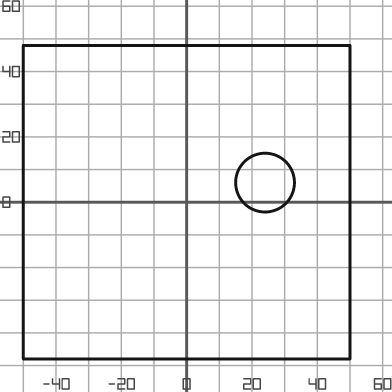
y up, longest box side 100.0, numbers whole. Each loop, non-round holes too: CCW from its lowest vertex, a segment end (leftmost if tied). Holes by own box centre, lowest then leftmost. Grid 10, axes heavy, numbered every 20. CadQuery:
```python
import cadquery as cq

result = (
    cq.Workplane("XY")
    .moveTo(-50.0, -48.0)
    .lineTo(50.0, -48.0)
    .lineTo(50.0, 48.0)
    .lineTo(-50.0, 48.0)
    .close()
    .moveTo(24.0, 6.0)
    .circle(9.0)
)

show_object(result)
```